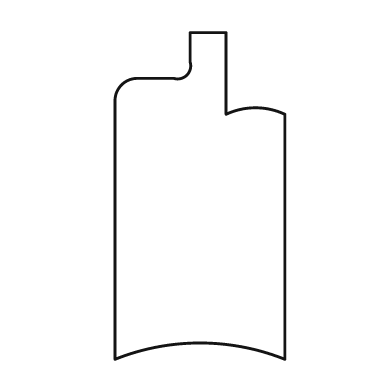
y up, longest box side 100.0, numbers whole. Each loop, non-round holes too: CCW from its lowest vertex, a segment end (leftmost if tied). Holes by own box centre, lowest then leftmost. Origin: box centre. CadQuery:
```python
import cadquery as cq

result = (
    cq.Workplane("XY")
    .moveTo(-26.0, -50.0)
    .threePointArc((0.0, -45.0), (26.0, -50.0))
    .lineTo(26.0, 25.0)
    .threePointArc((17.0, 27.0), (8.0, 25.0))
    .lineTo(8.0, 50.0)
    .lineTo(-3.0, 50.0)
    .lineTo(-3.0, 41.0)
    .threePointArc((-4.0, 37.0), (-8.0, 36.0))
    .lineTo(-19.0, 36.0)
    .threePointArc((-24.0, 34.0), (-26.0, 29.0))
    .close()
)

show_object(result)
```